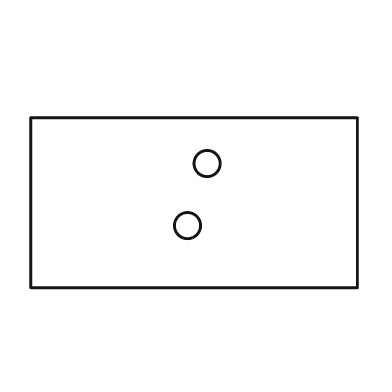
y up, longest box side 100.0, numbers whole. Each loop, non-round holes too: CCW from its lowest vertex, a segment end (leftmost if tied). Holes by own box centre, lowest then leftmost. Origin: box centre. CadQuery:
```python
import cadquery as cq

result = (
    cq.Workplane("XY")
    .moveTo(-50.0, -26.0)
    .lineTo(50.0, -26.0)
    .lineTo(50.0, 26.0)
    .lineTo(-50.0, 26.0)
    .close()
    .moveTo(-2.0, -7.0)
    .circle(4.0)
    .moveTo(4.0, 12.0)
    .circle(4.0)
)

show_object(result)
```